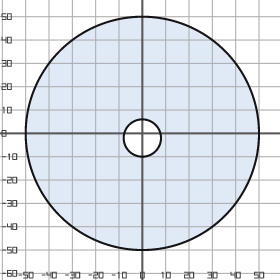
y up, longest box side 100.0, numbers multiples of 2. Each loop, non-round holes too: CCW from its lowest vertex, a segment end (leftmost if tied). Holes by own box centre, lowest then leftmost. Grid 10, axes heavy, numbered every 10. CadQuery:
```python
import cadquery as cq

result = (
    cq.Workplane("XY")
    .moveTo(0.0, 0.0)
    .circle(50.0)
    .moveTo(0.0, -2.0)
    .circle(8.0)
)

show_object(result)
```